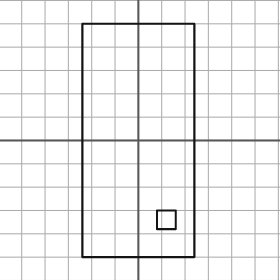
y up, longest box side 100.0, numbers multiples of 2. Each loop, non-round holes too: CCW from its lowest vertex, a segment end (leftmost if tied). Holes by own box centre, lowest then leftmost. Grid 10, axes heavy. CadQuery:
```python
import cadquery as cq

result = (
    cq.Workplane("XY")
    .moveTo(-24.0, -50.0)
    .lineTo(24.0, -50.0)
    .lineTo(24.0, 50.0)
    .lineTo(-24.0, 50.0)
    .close()
    .moveTo(8.0, -38.0)
    .lineTo(16.0, -38.0)
    .lineTo(16.0, -30.0)
    .lineTo(8.0, -30.0)
    .close()
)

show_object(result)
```